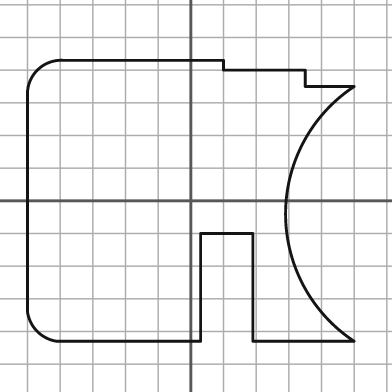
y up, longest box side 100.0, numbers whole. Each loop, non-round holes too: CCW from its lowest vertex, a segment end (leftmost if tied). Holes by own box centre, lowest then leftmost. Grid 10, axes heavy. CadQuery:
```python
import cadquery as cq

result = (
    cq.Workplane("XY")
    .moveTo(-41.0, -43.0)
    .lineTo(3.0, -43.0)
    .lineTo(3.0, -10.0)
    .lineTo(19.0, -10.0)
    .lineTo(19.0, -43.0)
    .lineTo(50.0, -43.0)
    .threePointArc((29.0, -4.0), (50.0, 35.0))
    .lineTo(35.0, 35.0)
    .lineTo(35.0, 40.0)
    .lineTo(10.0, 40.0)
    .lineTo(10.0, 43.0)
    .lineTo(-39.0, 43.0)
    .threePointArc((-47.0, 40.0), (-50.0, 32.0))
    .lineTo(-50.0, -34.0)
    .threePointArc((-47.0, -40.0), (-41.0, -43.0))
    .close()
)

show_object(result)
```